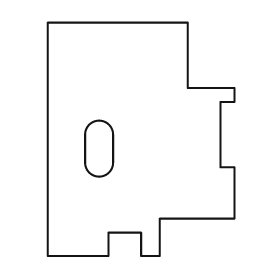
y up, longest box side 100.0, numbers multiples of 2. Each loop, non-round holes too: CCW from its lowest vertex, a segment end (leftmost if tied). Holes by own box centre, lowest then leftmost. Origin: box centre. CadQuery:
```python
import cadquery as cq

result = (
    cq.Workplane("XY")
    .moveTo(-40.0, -50.0)
    .lineTo(-14.0, -50.0)
    .lineTo(-14.0, -40.0)
    .lineTo(0.0, -40.0)
    .lineTo(0.0, -50.0)
    .lineTo(8.0, -50.0)
    .lineTo(8.0, -34.0)
    .lineTo(40.0, -34.0)
    .lineTo(40.0, -12.0)
    .lineTo(34.0, -12.0)
    .lineTo(34.0, 16.0)
    .lineTo(40.0, 16.0)
    .lineTo(40.0, 22.0)
    .lineTo(20.0, 22.0)
    .lineTo(20.0, 50.0)
    .lineTo(-40.0, 50.0)
    .close()
    .moveTo(-24.0, -10.0)
    .threePointArc((-18.0, -16.0), (-12.0, -10.0))
    .lineTo(-12.0, 2.0)
    .threePointArc((-18.0, 8.0), (-24.0, 2.0))
    .close()
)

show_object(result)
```